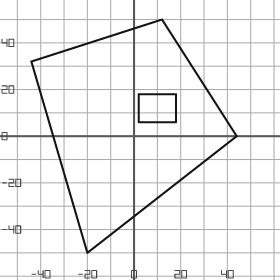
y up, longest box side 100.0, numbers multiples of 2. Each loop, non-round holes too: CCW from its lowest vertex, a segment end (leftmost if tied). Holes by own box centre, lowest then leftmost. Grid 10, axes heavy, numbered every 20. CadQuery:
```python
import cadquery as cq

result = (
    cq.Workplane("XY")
    .moveTo(-20.0, -50.0)
    .lineTo(44.0, 0.0)
    .lineTo(12.0, 50.0)
    .lineTo(-44.0, 32.0)
    .close()
    .moveTo(2.0, 6.0)
    .lineTo(18.0, 6.0)
    .lineTo(18.0, 18.0)
    .lineTo(2.0, 18.0)
    .close()
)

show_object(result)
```